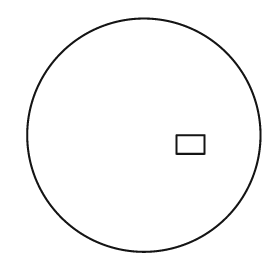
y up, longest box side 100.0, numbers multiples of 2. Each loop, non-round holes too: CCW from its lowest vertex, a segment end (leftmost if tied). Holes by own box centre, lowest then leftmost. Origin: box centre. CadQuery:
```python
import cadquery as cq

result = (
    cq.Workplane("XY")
    .moveTo(0.0, 0.0)
    .circle(50.0)
    .moveTo(14.0, -8.0)
    .lineTo(26.0, -8.0)
    .lineTo(26.0, 0.0)
    .lineTo(14.0, 0.0)
    .close()
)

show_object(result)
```